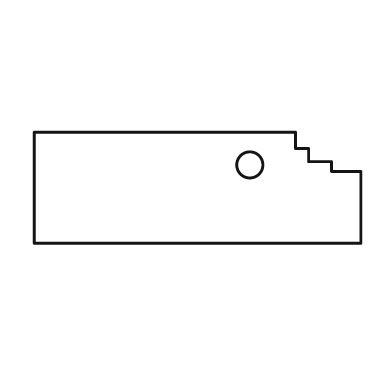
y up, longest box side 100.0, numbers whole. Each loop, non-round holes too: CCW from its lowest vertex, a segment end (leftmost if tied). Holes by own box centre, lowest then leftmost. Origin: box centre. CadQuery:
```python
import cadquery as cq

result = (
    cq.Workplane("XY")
    .moveTo(-50.0, -17.0)
    .lineTo(50.0, -17.0)
    .lineTo(50.0, 5.0)
    .lineTo(41.0, 5.0)
    .lineTo(41.0, 8.0)
    .lineTo(34.0, 8.0)
    .lineTo(34.0, 12.0)
    .lineTo(30.0, 12.0)
    .lineTo(30.0, 17.0)
    .lineTo(-50.0, 17.0)
    .close()
    .moveTo(16.0, 7.0)
    .circle(4.0)
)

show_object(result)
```